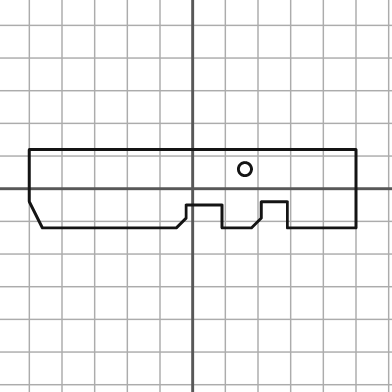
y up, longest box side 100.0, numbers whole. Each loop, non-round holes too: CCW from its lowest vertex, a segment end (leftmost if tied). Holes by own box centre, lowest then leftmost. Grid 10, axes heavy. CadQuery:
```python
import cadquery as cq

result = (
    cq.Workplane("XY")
    .moveTo(-46.0, -12.0)
    .lineTo(-5.0, -12.0)
    .lineTo(-2.0, -9.0)
    .lineTo(-2.0, -5.0)
    .lineTo(9.0, -5.0)
    .lineTo(9.0, -12.0)
    .lineTo(18.0, -12.0)
    .lineTo(21.0, -9.0)
    .lineTo(21.0, -4.0)
    .lineTo(29.0, -4.0)
    .lineTo(29.0, -12.0)
    .lineTo(50.0, -12.0)
    .lineTo(50.0, 12.0)
    .lineTo(-50.0, 12.0)
    .lineTo(-50.0, -4.0)
    .close()
    .moveTo(16.0, 6.0)
    .circle(2.0)
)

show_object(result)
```